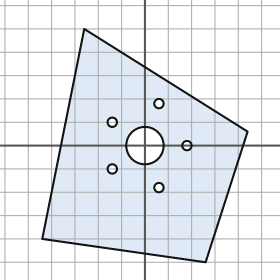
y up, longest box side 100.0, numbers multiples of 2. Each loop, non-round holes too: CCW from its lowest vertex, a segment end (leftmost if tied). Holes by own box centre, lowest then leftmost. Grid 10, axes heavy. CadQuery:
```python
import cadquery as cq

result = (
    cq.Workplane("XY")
    .moveTo(26.0, -50.0)
    .lineTo(44.0, 6.0)
    .lineTo(-26.0, 50.0)
    .lineTo(-44.0, -40.0)
    .close()
    .moveTo(6.0, -18.0)
    .circle(2.0)
    .moveTo(-14.0, -10.0)
    .circle(2.0)
    .moveTo(0.0, 0.0)
    .circle(8.0)
    .moveTo(18.0, 0.0)
    .circle(2.0)
    .moveTo(-14.0, 10.0)
    .circle(2.0)
    .moveTo(6.0, 18.0)
    .circle(2.0)
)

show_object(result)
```